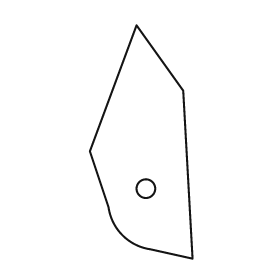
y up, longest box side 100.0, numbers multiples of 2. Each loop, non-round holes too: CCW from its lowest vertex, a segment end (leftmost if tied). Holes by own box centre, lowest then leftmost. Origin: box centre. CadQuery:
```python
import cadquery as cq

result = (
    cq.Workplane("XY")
    .moveTo(22.0, -50.0)
    .lineTo(18.0, 22.0)
    .lineTo(-2.0, 50.0)
    .lineTo(-22.0, -4.0)
    .lineTo(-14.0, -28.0)
    .threePointArc((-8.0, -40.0), (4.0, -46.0))
    .close()
    .moveTo(2.0, -20.0)
    .circle(4.0)
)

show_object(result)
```